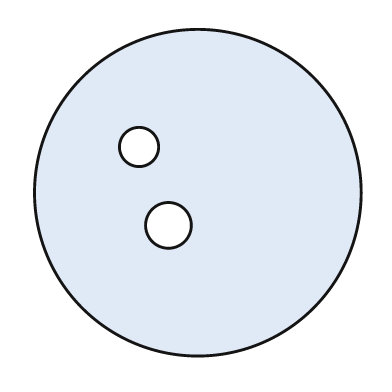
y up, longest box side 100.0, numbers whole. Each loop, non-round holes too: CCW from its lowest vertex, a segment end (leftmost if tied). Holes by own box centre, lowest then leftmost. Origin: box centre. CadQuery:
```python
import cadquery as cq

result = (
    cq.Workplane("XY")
    .moveTo(0.0, 0.0)
    .circle(50.0)
    .moveTo(-9.0, -10.0)
    .circle(7.0)
    .moveTo(-18.0, 14.0)
    .circle(6.0)
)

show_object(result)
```